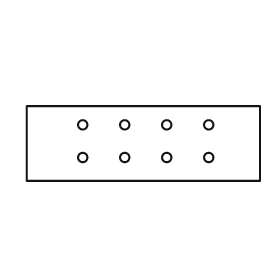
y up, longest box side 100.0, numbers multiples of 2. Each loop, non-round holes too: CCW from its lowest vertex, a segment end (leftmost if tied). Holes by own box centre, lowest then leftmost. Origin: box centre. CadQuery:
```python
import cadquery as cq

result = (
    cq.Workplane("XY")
    .moveTo(-50.0, -16.0)
    .lineTo(50.0, -16.0)
    .lineTo(50.0, 16.0)
    .lineTo(-50.0, 16.0)
    .close()
    .moveTo(-26.0, -6.0)
    .circle(2.0)
    .moveTo(-8.0, -6.0)
    .circle(2.0)
    .moveTo(10.0, -6.0)
    .circle(2.0)
    .moveTo(28.0, -6.0)
    .circle(2.0)
    .moveTo(-26.0, 8.0)
    .circle(2.0)
    .moveTo(-8.0, 8.0)
    .circle(2.0)
    .moveTo(10.0, 8.0)
    .circle(2.0)
    .moveTo(28.0, 8.0)
    .circle(2.0)
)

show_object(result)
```